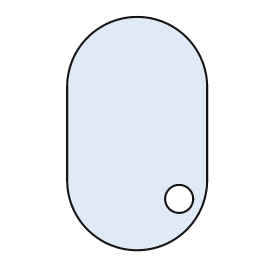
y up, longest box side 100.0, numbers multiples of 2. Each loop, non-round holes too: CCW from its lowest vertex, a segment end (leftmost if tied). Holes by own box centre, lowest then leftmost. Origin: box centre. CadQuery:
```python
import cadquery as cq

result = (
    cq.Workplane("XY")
    .moveTo(-30.0, -20.0)
    .threePointArc((0.0, -50.0), (30.0, -20.0))
    .lineTo(30.0, 20.0)
    .threePointArc((0.0, 50.0), (-30.0, 20.0))
    .close()
    .moveTo(18.0, -28.0)
    .circle(6.0)
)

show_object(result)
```